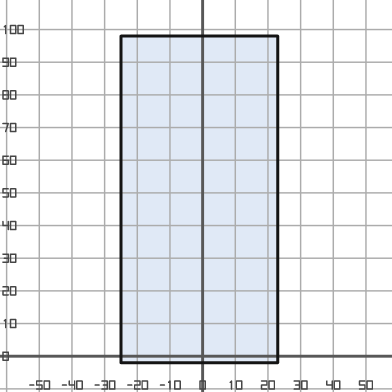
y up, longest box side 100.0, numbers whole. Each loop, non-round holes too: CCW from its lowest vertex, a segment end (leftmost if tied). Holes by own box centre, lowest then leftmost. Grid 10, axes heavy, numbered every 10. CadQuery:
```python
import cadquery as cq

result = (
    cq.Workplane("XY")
    .moveTo(-25.0, -2.0)
    .lineTo(23.0, -2.0)
    .lineTo(23.0, 98.0)
    .lineTo(-25.0, 98.0)
    .close()
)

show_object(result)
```